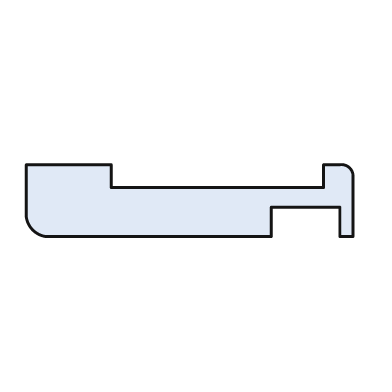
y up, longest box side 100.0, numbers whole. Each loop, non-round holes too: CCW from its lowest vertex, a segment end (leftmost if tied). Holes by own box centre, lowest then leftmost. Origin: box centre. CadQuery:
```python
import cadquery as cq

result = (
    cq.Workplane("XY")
    .moveTo(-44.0, -11.0)
    .lineTo(25.0, -11.0)
    .lineTo(25.0, -2.0)
    .lineTo(46.0, -2.0)
    .lineTo(46.0, -11.0)
    .lineTo(50.0, -11.0)
    .lineTo(50.0, 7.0)
    .threePointArc((49.0, 10.0), (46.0, 11.0))
    .lineTo(41.0, 11.0)
    .lineTo(41.0, 4.0)
    .lineTo(-24.0, 4.0)
    .lineTo(-24.0, 11.0)
    .lineTo(-50.0, 11.0)
    .lineTo(-50.0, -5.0)
    .threePointArc((-48.0, -9.0), (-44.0, -11.0))
    .close()
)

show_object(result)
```